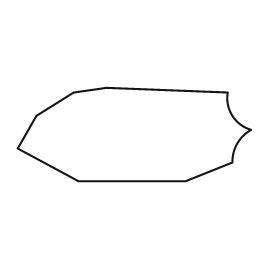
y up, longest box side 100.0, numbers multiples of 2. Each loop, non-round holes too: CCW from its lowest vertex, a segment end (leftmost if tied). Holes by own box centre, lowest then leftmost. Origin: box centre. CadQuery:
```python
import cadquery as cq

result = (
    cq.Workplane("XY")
    .moveTo(-24.0, -20.0)
    .lineTo(22.0, -20.0)
    .lineTo(42.0, -12.0)
    .threePointArc((44.0, -4.0), (50.0, 2.0))
    .threePointArc((42.0, 8.0), (40.0, 18.0))
    .lineTo(-12.0, 20.0)
    .lineTo(-26.0, 18.0)
    .lineTo(-42.0, 8.0)
    .lineTo(-50.0, -6.0)
    .close()
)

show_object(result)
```